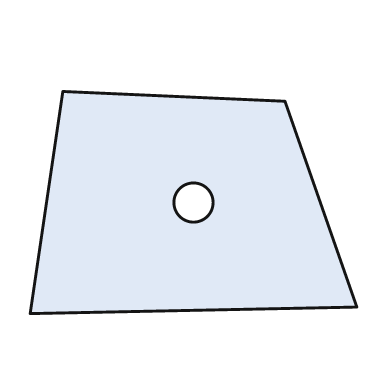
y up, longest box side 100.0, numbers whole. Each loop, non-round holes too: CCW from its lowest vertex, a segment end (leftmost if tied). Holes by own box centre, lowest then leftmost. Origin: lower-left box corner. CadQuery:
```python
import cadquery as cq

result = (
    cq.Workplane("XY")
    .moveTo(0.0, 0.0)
    .lineTo(100.0, 2.0)
    .lineTo(78.0, 65.0)
    .lineTo(10.0, 68.0)
    .close()
    .moveTo(50.0, 34.0)
    .circle(6.0)
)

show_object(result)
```